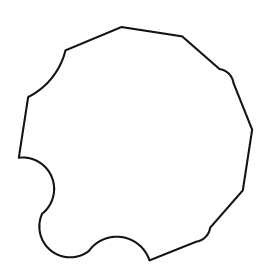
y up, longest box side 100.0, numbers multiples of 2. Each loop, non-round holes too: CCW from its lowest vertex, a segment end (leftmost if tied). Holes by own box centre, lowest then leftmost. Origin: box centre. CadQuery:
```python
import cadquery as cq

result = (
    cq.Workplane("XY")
    .moveTo(6.0, -50.0)
    .lineTo(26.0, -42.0)
    .threePointArc((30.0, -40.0), (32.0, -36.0))
    .lineTo(46.0, -20.0)
    .lineTo(50.0, 6.0)
    .lineTo(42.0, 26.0)
    .threePointArc((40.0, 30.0), (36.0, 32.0))
    .lineTo(20.0, 46.0)
    .lineTo(-6.0, 50.0)
    .lineTo(-30.0, 40.0)
    .threePointArc((-36.0, 28.0), (-46.0, 20.0))
    .lineTo(-50.0, -6.0)
    .threePointArc((-36.0, -14.0), (-40.0, -30.0))
    .threePointArc((-36.0, -46.0), (-20.0, -46.0))
    .threePointArc((-6.0, -40.0), (6.0, -50.0))
    .close()
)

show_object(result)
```